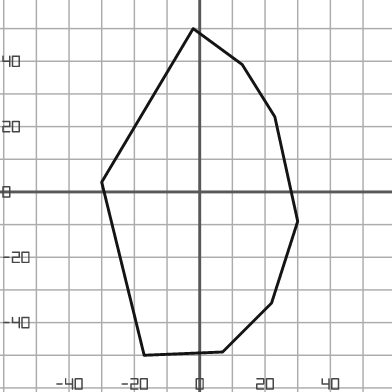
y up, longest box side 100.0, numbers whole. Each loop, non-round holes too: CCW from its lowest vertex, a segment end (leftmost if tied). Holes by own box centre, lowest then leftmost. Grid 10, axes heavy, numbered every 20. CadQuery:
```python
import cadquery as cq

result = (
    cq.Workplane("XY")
    .moveTo(-17.0, -50.0)
    .lineTo(7.0, -49.0)
    .lineTo(22.0, -34.0)
    .lineTo(30.0, -9.0)
    .lineTo(23.0, 23.0)
    .lineTo(13.0, 39.0)
    .lineTo(-2.0, 50.0)
    .lineTo(-30.0, 3.0)
    .close()
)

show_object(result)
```